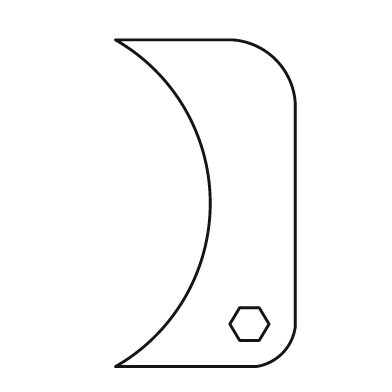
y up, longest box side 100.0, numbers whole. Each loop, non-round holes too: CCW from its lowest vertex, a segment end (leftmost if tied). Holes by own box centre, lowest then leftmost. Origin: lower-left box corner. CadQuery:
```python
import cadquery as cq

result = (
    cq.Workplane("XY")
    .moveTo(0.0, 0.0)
    .lineTo(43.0, 0.0)
    .threePointArc((51.0, 4.0), (55.0, 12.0))
    .lineTo(55.0, 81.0)
    .threePointArc((49.0, 94.0), (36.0, 100.0))
    .lineTo(0.0, 100.0)
    .threePointArc((29.0, 50.0), (0.0, 0.0))
    .close()
    .moveTo(38.0, 8.0)
    .lineTo(44.0, 8.0)
    .lineTo(47.0, 13.0)
    .lineTo(44.0, 18.0)
    .lineTo(38.0, 18.0)
    .lineTo(35.0, 13.0)
    .close()
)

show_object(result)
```